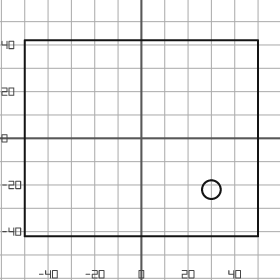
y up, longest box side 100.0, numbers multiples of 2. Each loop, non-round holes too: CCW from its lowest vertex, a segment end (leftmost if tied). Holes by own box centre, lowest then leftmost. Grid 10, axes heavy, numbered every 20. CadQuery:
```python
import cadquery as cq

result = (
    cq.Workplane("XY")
    .moveTo(-50.0, -42.0)
    .lineTo(50.0, -42.0)
    .lineTo(50.0, 42.0)
    .lineTo(-50.0, 42.0)
    .close()
    .moveTo(30.0, -22.0)
    .circle(4.0)
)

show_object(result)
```